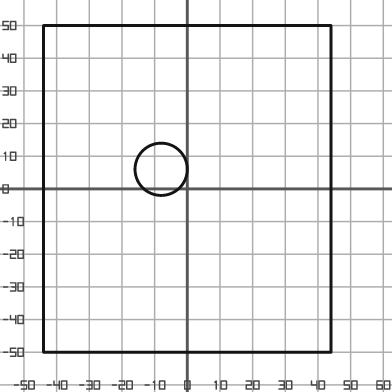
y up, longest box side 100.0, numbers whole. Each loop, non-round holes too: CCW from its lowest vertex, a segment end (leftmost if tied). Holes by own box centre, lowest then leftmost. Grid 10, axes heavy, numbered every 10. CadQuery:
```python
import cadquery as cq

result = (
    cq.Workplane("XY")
    .moveTo(-44.0, -50.0)
    .lineTo(44.0, -50.0)
    .lineTo(44.0, 50.0)
    .lineTo(-44.0, 50.0)
    .close()
    .moveTo(-8.0, 6.0)
    .circle(8.0)
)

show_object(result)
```